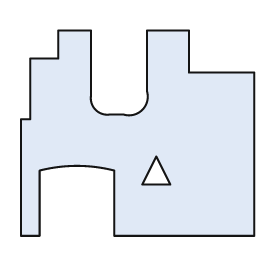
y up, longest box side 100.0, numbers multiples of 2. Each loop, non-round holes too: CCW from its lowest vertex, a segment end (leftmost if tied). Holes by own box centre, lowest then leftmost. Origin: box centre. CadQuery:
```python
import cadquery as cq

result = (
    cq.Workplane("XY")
    .moveTo(-50.0, -44.0)
    .lineTo(-42.0, -44.0)
    .lineTo(-42.0, -16.0)
    .threePointArc((-26.0, -14.0), (-10.0, -16.0))
    .lineTo(-10.0, -44.0)
    .lineTo(50.0, -44.0)
    .lineTo(50.0, 26.0)
    .lineTo(22.0, 26.0)
    .lineTo(22.0, 44.0)
    .lineTo(4.0, 44.0)
    .lineTo(4.0, 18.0)
    .threePointArc((2.0, 10.0), (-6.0, 8.0))
    .lineTo(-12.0, 8.0)
    .threePointArc((-18.0, 10.0), (-20.0, 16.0))
    .lineTo(-20.0, 44.0)
    .lineTo(-34.0, 44.0)
    .lineTo(-34.0, 32.0)
    .lineTo(-46.0, 32.0)
    .lineTo(-46.0, 6.0)
    .lineTo(-50.0, 6.0)
    .close()
    .moveTo(2.0, -22.0)
    .lineTo(14.0, -22.0)
    .lineTo(8.0, -10.0)
    .close()
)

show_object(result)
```